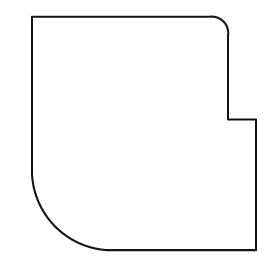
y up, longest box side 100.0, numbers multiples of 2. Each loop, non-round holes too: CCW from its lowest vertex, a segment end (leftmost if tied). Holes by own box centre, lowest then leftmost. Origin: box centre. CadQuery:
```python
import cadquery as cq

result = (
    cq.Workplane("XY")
    .moveTo(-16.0, -50.0)
    .lineTo(48.0, -50.0)
    .lineTo(48.0, 6.0)
    .lineTo(36.0, 6.0)
    .lineTo(36.0, 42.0)
    .threePointArc((34.0, 48.0), (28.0, 50.0))
    .lineTo(-48.0, 50.0)
    .lineTo(-48.0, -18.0)
    .threePointArc((-38.0, -40.0), (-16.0, -50.0))
    .close()
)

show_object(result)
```